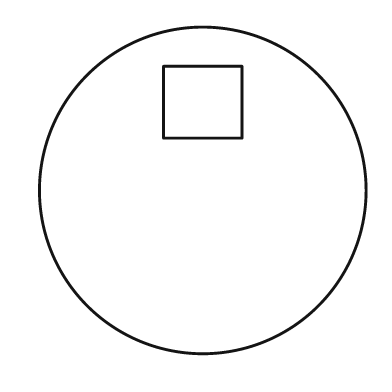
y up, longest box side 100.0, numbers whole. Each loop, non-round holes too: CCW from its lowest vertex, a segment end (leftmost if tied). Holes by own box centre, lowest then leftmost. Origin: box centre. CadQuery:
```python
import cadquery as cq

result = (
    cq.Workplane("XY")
    .moveTo(0.0, 0.0)
    .circle(50.0)
    .moveTo(-12.0, 16.0)
    .lineTo(12.0, 16.0)
    .lineTo(12.0, 38.0)
    .lineTo(-12.0, 38.0)
    .close()
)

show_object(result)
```